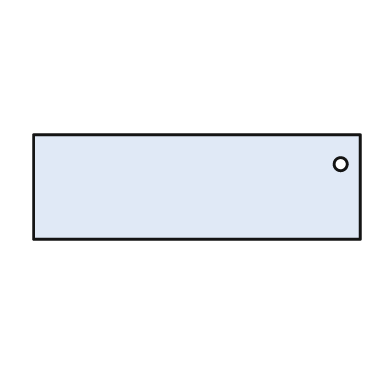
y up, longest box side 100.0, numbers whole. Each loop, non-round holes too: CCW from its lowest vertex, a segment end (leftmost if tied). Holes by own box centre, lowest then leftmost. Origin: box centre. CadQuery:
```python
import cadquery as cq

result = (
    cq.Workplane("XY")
    .moveTo(-50.0, -16.0)
    .lineTo(50.0, -16.0)
    .lineTo(50.0, 16.0)
    .lineTo(-50.0, 16.0)
    .close()
    .moveTo(44.0, 7.0)
    .circle(2.0)
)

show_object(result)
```